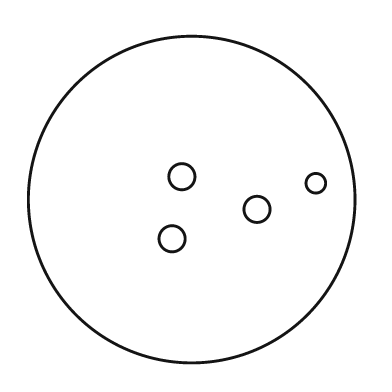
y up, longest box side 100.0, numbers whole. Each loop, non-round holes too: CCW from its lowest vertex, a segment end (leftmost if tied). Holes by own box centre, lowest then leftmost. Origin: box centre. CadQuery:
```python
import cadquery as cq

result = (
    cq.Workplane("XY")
    .moveTo(0.0, 0.0)
    .circle(50.0)
    .moveTo(-6.0, -12.0)
    .circle(4.0)
    .moveTo(20.0, -3.0)
    .circle(4.0)
    .moveTo(38.0, 5.0)
    .circle(3.0)
    .moveTo(-3.0, 7.0)
    .circle(4.0)
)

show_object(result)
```